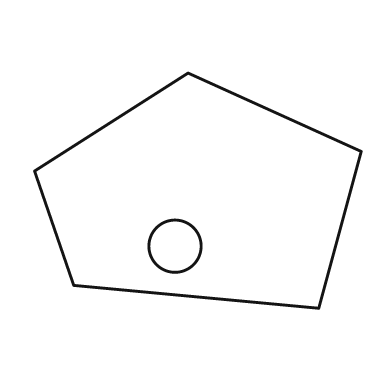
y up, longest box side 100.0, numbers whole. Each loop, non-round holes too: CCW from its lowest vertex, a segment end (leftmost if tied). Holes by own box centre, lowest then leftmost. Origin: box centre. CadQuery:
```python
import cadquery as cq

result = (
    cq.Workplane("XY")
    .moveTo(37.0, -36.0)
    .lineTo(50.0, 12.0)
    .lineTo(-3.0, 36.0)
    .lineTo(-50.0, 6.0)
    .lineTo(-38.0, -29.0)
    .close()
    .moveTo(-7.0, -17.0)
    .circle(8.0)
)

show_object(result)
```